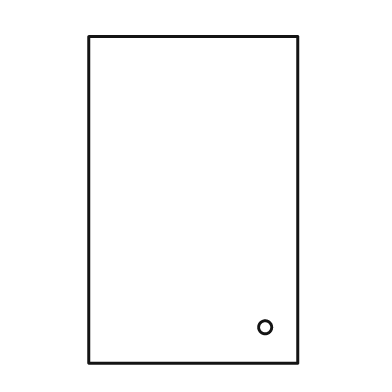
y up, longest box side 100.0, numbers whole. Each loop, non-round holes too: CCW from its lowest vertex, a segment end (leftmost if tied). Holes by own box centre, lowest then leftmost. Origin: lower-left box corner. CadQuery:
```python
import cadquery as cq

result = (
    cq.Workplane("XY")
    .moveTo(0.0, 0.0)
    .lineTo(64.0, 0.0)
    .lineTo(64.0, 100.0)
    .lineTo(0.0, 100.0)
    .close()
    .moveTo(54.0, 11.0)
    .circle(2.0)
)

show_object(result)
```